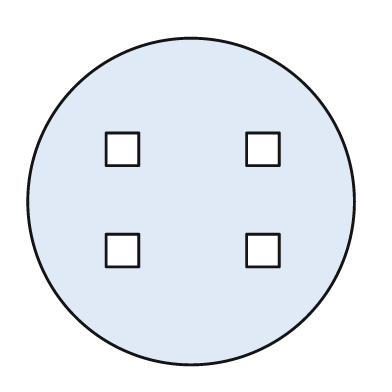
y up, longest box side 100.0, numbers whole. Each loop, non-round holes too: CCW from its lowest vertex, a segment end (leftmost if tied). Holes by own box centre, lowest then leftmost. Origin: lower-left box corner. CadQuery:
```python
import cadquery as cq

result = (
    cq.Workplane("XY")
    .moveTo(50.0, 50.0)
    .circle(50.0)
    .moveTo(24.0, 30.0)
    .lineTo(34.0, 30.0)
    .lineTo(34.0, 40.0)
    .lineTo(24.0, 40.0)
    .close()
    .moveTo(67.0, 30.0)
    .lineTo(77.0, 30.0)
    .lineTo(77.0, 40.0)
    .lineTo(67.0, 40.0)
    .close()
    .moveTo(24.0, 61.0)
    .lineTo(34.0, 61.0)
    .lineTo(34.0, 71.0)
    .lineTo(24.0, 71.0)
    .close()
    .moveTo(67.0, 61.0)
    .lineTo(77.0, 61.0)
    .lineTo(77.0, 71.0)
    .lineTo(67.0, 71.0)
    .close()
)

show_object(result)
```